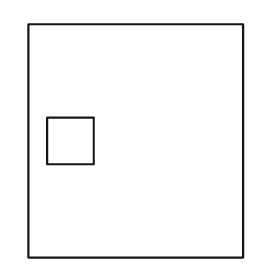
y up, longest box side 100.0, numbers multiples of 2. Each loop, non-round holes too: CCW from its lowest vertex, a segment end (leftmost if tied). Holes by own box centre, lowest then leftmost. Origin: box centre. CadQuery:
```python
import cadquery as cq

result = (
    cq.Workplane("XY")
    .moveTo(-46.0, -50.0)
    .lineTo(46.0, -50.0)
    .lineTo(46.0, 50.0)
    .lineTo(-46.0, 50.0)
    .close()
    .moveTo(-38.0, -10.0)
    .lineTo(-18.0, -10.0)
    .lineTo(-18.0, 10.0)
    .lineTo(-38.0, 10.0)
    .close()
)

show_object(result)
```